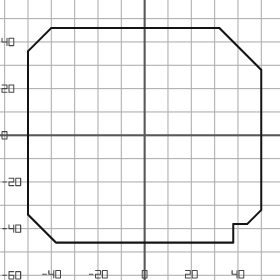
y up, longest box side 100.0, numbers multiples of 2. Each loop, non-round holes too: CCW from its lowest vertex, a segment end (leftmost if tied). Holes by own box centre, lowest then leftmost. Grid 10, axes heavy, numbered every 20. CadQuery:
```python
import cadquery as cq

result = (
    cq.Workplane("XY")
    .moveTo(-38.0, -46.0)
    .lineTo(38.0, -46.0)
    .lineTo(38.0, -38.0)
    .lineTo(44.0, -38.0)
    .lineTo(50.0, -32.0)
    .lineTo(50.0, 28.0)
    .lineTo(32.0, 46.0)
    .lineTo(-40.0, 46.0)
    .lineTo(-50.0, 36.0)
    .lineTo(-50.0, -34.0)
    .close()
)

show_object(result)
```